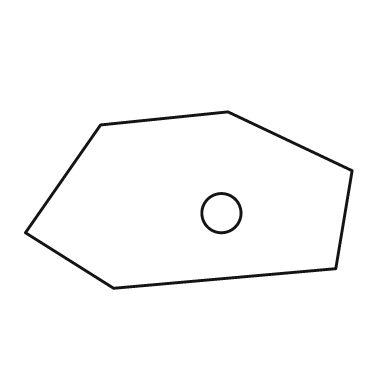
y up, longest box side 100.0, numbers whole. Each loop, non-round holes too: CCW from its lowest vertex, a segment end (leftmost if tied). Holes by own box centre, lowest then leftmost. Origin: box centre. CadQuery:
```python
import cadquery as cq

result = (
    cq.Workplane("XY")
    .moveTo(-23.0, -27.0)
    .lineTo(45.0, -21.0)
    .lineTo(50.0, 9.0)
    .lineTo(12.0, 27.0)
    .lineTo(-27.0, 23.0)
    .lineTo(-50.0, -10.0)
    .close()
    .moveTo(10.0, -4.0)
    .circle(6.0)
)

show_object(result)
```